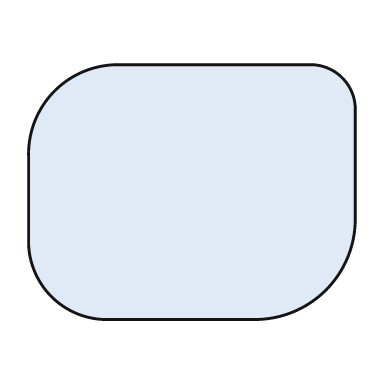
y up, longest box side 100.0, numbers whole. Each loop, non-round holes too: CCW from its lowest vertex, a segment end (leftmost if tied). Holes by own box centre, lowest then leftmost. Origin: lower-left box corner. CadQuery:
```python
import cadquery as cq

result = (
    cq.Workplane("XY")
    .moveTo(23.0, 0.0)
    .lineTo(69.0, 0.0)
    .threePointArc((91.0, 9.0), (100.0, 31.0))
    .lineTo(100.0, 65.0)
    .threePointArc((96.0, 74.0), (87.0, 78.0))
    .lineTo(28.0, 78.0)
    .threePointArc((8.0, 70.0), (0.0, 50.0))
    .lineTo(0.0, 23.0)
    .threePointArc((7.0, 7.0), (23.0, 0.0))
    .close()
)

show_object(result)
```